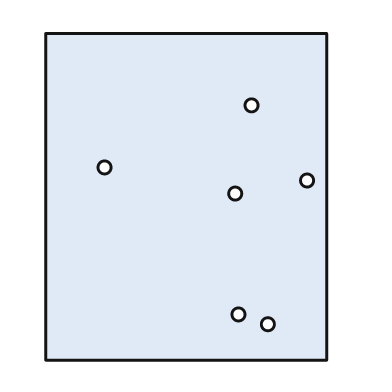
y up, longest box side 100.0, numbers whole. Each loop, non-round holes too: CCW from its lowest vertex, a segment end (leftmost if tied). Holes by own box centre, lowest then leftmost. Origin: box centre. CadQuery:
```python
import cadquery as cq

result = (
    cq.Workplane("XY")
    .moveTo(-43.0, -50.0)
    .lineTo(43.0, -50.0)
    .lineTo(43.0, 50.0)
    .lineTo(-43.0, 50.0)
    .close()
    .moveTo(25.0, -39.0)
    .circle(2.0)
    .moveTo(16.0, -36.0)
    .circle(2.0)
    .moveTo(15.0, 1.0)
    .circle(2.0)
    .moveTo(37.0, 5.0)
    .circle(2.0)
    .moveTo(-25.0, 9.0)
    .circle(2.0)
    .moveTo(20.0, 28.0)
    .circle(2.0)
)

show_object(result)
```